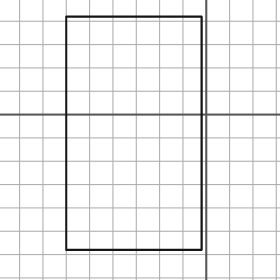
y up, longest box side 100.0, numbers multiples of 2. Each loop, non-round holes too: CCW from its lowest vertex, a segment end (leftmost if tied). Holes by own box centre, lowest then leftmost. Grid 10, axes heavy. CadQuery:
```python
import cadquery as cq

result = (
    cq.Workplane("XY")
    .moveTo(-60.0, -58.0)
    .lineTo(-2.0, -58.0)
    .lineTo(-2.0, 42.0)
    .lineTo(-60.0, 42.0)
    .close()
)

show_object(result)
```